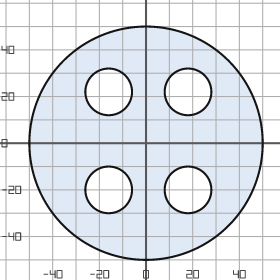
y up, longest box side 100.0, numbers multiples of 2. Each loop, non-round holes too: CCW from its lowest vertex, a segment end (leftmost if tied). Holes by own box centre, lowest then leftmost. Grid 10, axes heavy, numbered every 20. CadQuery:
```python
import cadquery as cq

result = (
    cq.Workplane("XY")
    .moveTo(0.0, 0.0)
    .circle(50.0)
    .moveTo(-16.0, -20.0)
    .circle(10.0)
    .moveTo(18.0, -20.0)
    .circle(10.0)
    .moveTo(-16.0, 22.0)
    .circle(10.0)
    .moveTo(18.0, 22.0)
    .circle(10.0)
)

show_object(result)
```